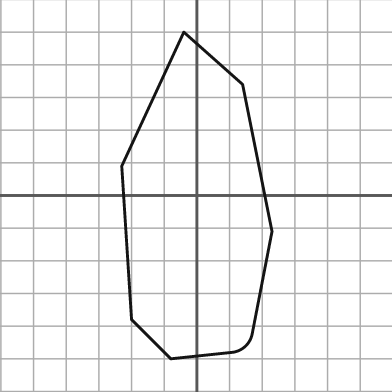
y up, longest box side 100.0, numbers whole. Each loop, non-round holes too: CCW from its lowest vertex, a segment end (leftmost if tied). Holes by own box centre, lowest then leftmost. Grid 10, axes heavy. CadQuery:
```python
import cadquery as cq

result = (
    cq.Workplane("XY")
    .moveTo(-8.0, -50.0)
    .lineTo(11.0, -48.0)
    .threePointArc((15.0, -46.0), (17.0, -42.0))
    .lineTo(23.0, -11.0)
    .lineTo(14.0, 34.0)
    .lineTo(-4.0, 50.0)
    .lineTo(-23.0, 9.0)
    .lineTo(-20.0, -38.0)
    .close()
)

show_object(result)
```